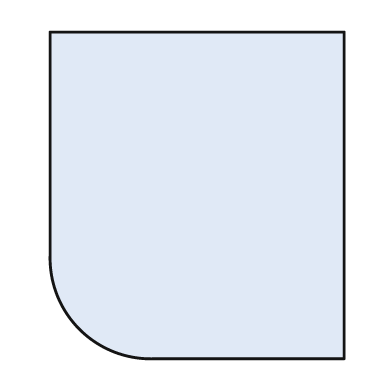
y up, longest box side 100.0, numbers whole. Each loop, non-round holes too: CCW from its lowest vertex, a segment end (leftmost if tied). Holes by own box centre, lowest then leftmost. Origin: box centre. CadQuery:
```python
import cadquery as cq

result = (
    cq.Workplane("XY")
    .moveTo(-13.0, -50.0)
    .lineTo(45.0, -50.0)
    .lineTo(45.0, 50.0)
    .lineTo(-45.0, 50.0)
    .lineTo(-45.0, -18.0)
    .threePointArc((-36.0, -41.0), (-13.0, -50.0))
    .close()
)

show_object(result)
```